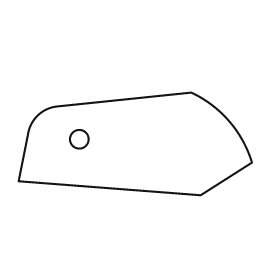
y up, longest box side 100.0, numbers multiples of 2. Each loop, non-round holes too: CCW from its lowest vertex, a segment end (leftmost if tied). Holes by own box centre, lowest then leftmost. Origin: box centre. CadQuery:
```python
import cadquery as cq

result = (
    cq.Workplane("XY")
    .moveTo(28.0, -22.0)
    .lineTo(50.0, -8.0)
    .threePointArc((40.0, 10.0), (24.0, 22.0))
    .lineTo(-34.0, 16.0)
    .threePointArc((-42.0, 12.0), (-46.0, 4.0))
    .lineTo(-50.0, -16.0)
    .close()
    .moveTo(-24.0, 2.0)
    .circle(4.0)
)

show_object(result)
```